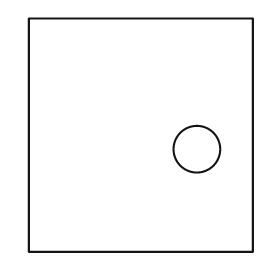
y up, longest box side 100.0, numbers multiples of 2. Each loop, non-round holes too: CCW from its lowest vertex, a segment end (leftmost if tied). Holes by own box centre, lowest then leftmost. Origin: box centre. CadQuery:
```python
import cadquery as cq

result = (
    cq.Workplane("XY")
    .moveTo(-48.0, -50.0)
    .lineTo(48.0, -50.0)
    .lineTo(48.0, 50.0)
    .lineTo(-48.0, 50.0)
    .close()
    .moveTo(24.0, -6.0)
    .circle(10.0)
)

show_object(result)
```